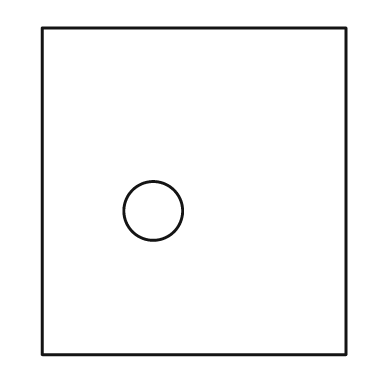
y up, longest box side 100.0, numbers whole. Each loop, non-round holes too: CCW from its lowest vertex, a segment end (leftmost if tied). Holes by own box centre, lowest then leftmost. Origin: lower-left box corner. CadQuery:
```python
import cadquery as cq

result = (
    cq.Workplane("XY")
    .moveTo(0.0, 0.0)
    .lineTo(93.0, 0.0)
    .lineTo(93.0, 100.0)
    .lineTo(0.0, 100.0)
    .close()
    .moveTo(34.0, 44.0)
    .circle(9.0)
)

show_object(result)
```